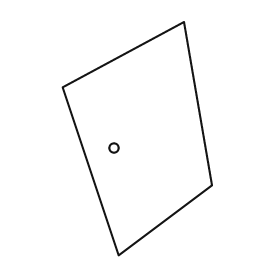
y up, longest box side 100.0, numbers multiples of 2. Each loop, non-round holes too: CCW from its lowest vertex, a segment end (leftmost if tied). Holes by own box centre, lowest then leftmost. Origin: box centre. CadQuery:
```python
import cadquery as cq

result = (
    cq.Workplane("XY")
    .moveTo(-8.0, -50.0)
    .lineTo(32.0, -20.0)
    .lineTo(20.0, 50.0)
    .lineTo(-32.0, 22.0)
    .close()
    .moveTo(-10.0, -4.0)
    .circle(2.0)
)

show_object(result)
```